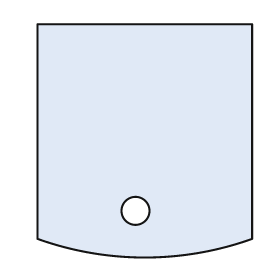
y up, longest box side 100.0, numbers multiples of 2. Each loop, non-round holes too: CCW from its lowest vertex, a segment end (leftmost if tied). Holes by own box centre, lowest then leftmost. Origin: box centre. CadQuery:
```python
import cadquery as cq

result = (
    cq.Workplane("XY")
    .moveTo(-46.0, -42.0)
    .threePointArc((0.0, -50.0), (46.0, -42.0))
    .lineTo(46.0, 50.0)
    .lineTo(-46.0, 50.0)
    .close()
    .moveTo(-4.0, -30.0)
    .circle(6.0)
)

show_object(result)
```